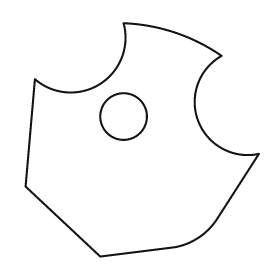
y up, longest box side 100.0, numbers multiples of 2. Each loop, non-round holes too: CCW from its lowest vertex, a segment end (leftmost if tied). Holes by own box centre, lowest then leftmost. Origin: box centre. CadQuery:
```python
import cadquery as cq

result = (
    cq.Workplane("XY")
    .moveTo(-18.0, -50.0)
    .lineTo(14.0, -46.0)
    .threePointArc((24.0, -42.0), (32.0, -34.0))
    .lineTo(50.0, -6.0)
    .threePointArc((24.0, 8.0), (34.0, 36.0))
    .threePointArc((14.0, 46.0), (-8.0, 50.0))
    .threePointArc((-18.0, 24.0), (-46.0, 26.0))
    .lineTo(-50.0, -20.0)
    .close()
    .moveTo(-8.0, 10.0)
    .circle(10.0)
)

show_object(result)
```